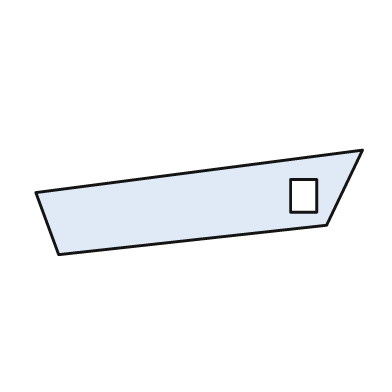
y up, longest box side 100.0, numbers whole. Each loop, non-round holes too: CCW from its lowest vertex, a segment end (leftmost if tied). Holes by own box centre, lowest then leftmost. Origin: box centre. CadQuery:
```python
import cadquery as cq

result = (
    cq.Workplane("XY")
    .moveTo(-43.0, -16.0)
    .lineTo(39.0, -7.0)
    .lineTo(50.0, 16.0)
    .lineTo(-50.0, 3.0)
    .close()
    .moveTo(28.0, -3.0)
    .lineTo(36.0, -3.0)
    .lineTo(36.0, 7.0)
    .lineTo(28.0, 7.0)
    .close()
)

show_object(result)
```